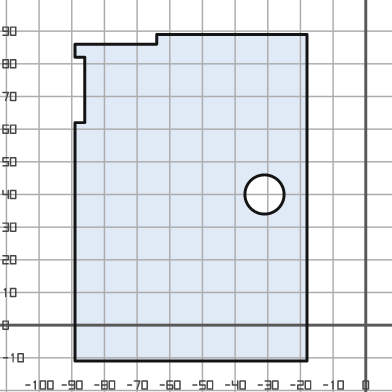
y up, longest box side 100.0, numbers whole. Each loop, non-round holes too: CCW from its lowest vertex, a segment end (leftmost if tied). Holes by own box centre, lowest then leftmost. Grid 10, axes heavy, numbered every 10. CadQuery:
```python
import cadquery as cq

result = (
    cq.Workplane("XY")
    .moveTo(-89.0, -11.0)
    .lineTo(-18.0, -11.0)
    .lineTo(-18.0, 89.0)
    .lineTo(-64.0, 89.0)
    .lineTo(-64.0, 86.0)
    .lineTo(-89.0, 86.0)
    .lineTo(-89.0, 82.0)
    .lineTo(-86.0, 82.0)
    .lineTo(-86.0, 62.0)
    .lineTo(-89.0, 62.0)
    .close()
    .moveTo(-31.0, 40.0)
    .circle(6.0)
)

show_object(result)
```